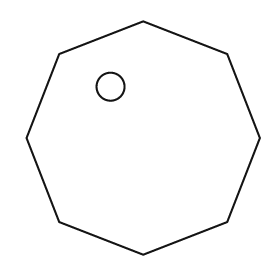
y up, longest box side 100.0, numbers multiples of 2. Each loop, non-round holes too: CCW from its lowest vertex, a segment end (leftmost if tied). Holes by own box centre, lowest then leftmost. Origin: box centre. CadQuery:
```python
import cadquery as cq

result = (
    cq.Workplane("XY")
    .moveTo(0.0, -50.0)
    .lineTo(36.0, -36.0)
    .lineTo(50.0, 0.0)
    .lineTo(36.0, 36.0)
    .lineTo(0.0, 50.0)
    .lineTo(-36.0, 36.0)
    .lineTo(-50.0, 0.0)
    .lineTo(-36.0, -36.0)
    .close()
    .moveTo(-14.0, 22.0)
    .circle(6.0)
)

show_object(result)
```